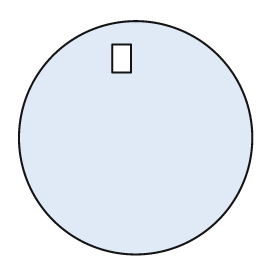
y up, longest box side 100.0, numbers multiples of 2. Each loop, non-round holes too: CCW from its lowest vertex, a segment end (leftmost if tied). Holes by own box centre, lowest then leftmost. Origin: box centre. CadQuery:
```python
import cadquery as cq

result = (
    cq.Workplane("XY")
    .moveTo(0.0, 0.0)
    .circle(50.0)
    .moveTo(-10.0, 28.0)
    .lineTo(-2.0, 28.0)
    .lineTo(-2.0, 40.0)
    .lineTo(-10.0, 40.0)
    .close()
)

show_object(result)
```